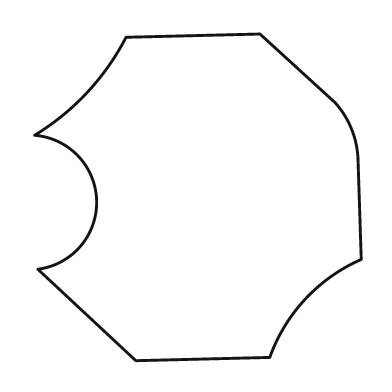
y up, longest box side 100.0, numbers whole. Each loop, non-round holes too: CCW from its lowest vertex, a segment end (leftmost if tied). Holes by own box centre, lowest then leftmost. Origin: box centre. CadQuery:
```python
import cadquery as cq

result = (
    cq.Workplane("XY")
    .moveTo(-19.0, -50.0)
    .lineTo(22.0, -49.0)
    .threePointArc((33.0, -31.0), (50.0, -19.0))
    .lineTo(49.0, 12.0)
    .threePointArc((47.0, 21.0), (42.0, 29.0))
    .lineTo(19.0, 50.0)
    .lineTo(-22.0, 49.0)
    .threePointArc((-34.0, 32.0), (-50.0, 19.0))
    .threePointArc((-31.0, -1.0), (-49.0, -22.0))
    .close()
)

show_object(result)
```